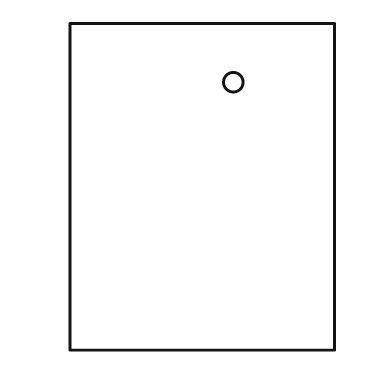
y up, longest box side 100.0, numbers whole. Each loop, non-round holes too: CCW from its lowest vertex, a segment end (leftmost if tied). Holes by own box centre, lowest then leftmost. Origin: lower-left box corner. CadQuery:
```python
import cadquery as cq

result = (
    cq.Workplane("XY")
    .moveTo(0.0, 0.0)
    .lineTo(81.0, 0.0)
    .lineTo(81.0, 100.0)
    .lineTo(0.0, 100.0)
    .close()
    .moveTo(50.0, 82.0)
    .circle(3.0)
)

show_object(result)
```